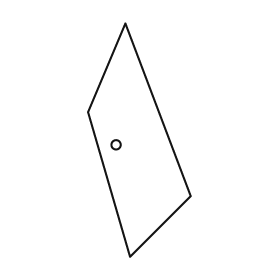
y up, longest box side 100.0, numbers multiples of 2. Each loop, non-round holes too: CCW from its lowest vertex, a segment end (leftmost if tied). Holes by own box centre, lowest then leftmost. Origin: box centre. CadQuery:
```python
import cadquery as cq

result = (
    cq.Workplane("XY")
    .moveTo(-4.0, -50.0)
    .lineTo(22.0, -24.0)
    .lineTo(-6.0, 50.0)
    .lineTo(-22.0, 12.0)
    .close()
    .moveTo(-10.0, -2.0)
    .circle(2.0)
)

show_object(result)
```